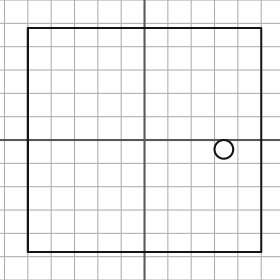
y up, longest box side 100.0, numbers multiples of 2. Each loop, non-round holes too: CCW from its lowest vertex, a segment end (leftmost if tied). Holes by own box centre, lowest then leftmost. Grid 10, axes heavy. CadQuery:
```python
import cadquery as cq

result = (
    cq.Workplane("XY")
    .moveTo(-50.0, -48.0)
    .lineTo(50.0, -48.0)
    .lineTo(50.0, 48.0)
    .lineTo(-50.0, 48.0)
    .close()
    .moveTo(34.0, -4.0)
    .circle(4.0)
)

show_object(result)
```